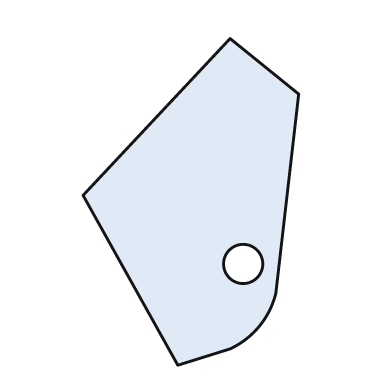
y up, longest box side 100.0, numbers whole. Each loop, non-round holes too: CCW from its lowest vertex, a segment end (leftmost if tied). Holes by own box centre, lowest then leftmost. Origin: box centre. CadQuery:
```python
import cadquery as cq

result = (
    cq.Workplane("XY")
    .moveTo(-4.0, -50.0)
    .lineTo(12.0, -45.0)
    .threePointArc((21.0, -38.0), (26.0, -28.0))
    .lineTo(33.0, 33.0)
    .lineTo(12.0, 50.0)
    .lineTo(-33.0, 2.0)
    .close()
    .moveTo(16.0, -19.0)
    .circle(6.0)
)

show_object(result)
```